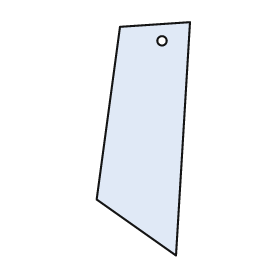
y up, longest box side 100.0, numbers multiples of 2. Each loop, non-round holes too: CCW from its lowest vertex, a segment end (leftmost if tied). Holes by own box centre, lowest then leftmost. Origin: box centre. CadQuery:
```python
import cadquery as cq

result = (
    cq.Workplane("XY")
    .moveTo(14.0, -50.0)
    .lineTo(20.0, 50.0)
    .lineTo(-10.0, 48.0)
    .lineTo(-20.0, -26.0)
    .close()
    .moveTo(8.0, 42.0)
    .circle(2.0)
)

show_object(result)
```